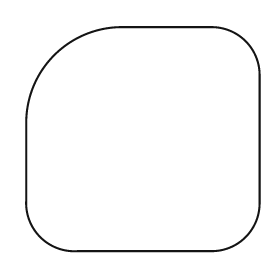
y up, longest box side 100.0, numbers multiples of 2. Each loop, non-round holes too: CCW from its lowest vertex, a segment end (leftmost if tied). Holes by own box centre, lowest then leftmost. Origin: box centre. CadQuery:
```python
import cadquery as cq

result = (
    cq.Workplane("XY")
    .moveTo(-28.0, -48.0)
    .lineTo(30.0, -48.0)
    .threePointArc((44.0, -42.0), (50.0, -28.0))
    .lineTo(50.0, 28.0)
    .threePointArc((44.0, 42.0), (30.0, 48.0))
    .lineTo(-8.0, 48.0)
    .threePointArc((-38.0, 36.0), (-50.0, 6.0))
    .lineTo(-50.0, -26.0)
    .threePointArc((-44.0, -42.0), (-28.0, -48.0))
    .close()
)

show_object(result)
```